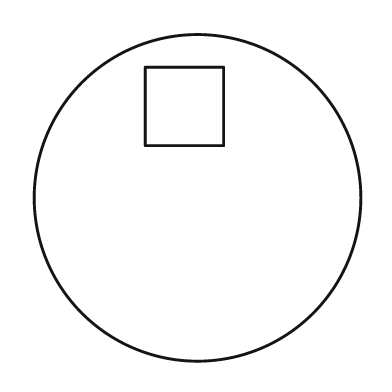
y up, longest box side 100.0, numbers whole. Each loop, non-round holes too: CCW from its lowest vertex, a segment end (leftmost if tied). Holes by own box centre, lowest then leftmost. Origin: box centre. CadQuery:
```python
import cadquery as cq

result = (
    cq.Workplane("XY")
    .moveTo(0.0, 0.0)
    .circle(50.0)
    .moveTo(-16.0, 16.0)
    .lineTo(8.0, 16.0)
    .lineTo(8.0, 40.0)
    .lineTo(-16.0, 40.0)
    .close()
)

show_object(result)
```